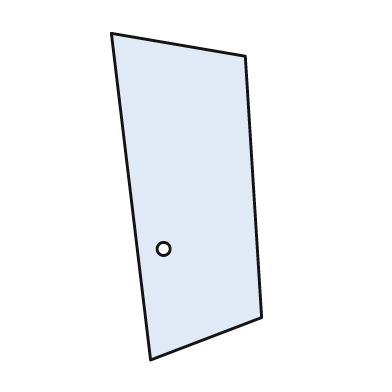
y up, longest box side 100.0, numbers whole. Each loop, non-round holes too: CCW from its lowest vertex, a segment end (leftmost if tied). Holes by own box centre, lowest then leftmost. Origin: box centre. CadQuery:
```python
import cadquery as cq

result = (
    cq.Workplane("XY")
    .moveTo(-11.0, -50.0)
    .lineTo(23.0, -37.0)
    .lineTo(18.0, 43.0)
    .lineTo(-23.0, 50.0)
    .close()
    .moveTo(-7.0, -16.0)
    .circle(2.0)
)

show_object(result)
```